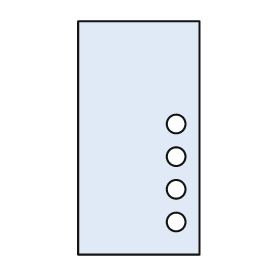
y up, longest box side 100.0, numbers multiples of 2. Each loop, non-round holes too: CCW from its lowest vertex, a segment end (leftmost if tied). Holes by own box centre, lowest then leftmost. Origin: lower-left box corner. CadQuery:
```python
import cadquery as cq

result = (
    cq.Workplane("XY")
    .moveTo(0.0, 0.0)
    .lineTo(52.0, 0.0)
    .lineTo(52.0, 100.0)
    .lineTo(0.0, 100.0)
    .close()
    .moveTo(42.0, 14.0)
    .circle(4.0)
    .moveTo(42.0, 28.0)
    .circle(4.0)
    .moveTo(42.0, 42.0)
    .circle(4.0)
    .moveTo(42.0, 56.0)
    .circle(4.0)
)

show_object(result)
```